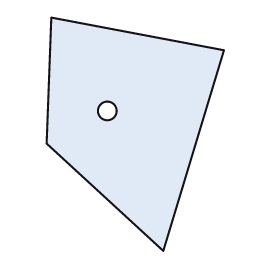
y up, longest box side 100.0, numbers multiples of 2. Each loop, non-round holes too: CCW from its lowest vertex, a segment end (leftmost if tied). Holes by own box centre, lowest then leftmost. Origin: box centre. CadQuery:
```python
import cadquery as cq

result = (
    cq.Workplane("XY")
    .moveTo(12.0, -50.0)
    .lineTo(38.0, 36.0)
    .lineTo(-36.0, 50.0)
    .lineTo(-38.0, -4.0)
    .close()
    .moveTo(-12.0, 10.0)
    .circle(4.0)
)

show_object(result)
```